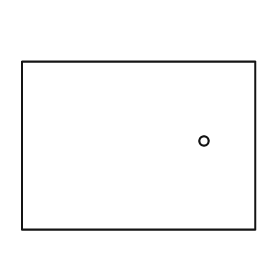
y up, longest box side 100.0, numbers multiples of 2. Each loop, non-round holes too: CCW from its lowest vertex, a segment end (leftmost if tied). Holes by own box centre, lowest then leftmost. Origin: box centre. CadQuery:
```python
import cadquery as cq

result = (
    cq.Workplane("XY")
    .moveTo(-50.0, -36.0)
    .lineTo(50.0, -36.0)
    .lineTo(50.0, 36.0)
    .lineTo(-50.0, 36.0)
    .close()
    .moveTo(28.0, 2.0)
    .circle(2.0)
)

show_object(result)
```